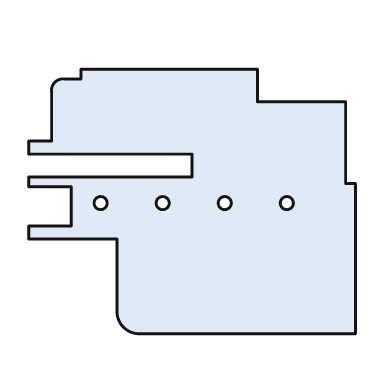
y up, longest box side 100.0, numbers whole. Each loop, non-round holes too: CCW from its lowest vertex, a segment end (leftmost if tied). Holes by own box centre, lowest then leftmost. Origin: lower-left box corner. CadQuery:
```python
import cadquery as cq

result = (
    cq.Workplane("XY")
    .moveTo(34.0, 0.0)
    .lineTo(100.0, 0.0)
    .lineTo(100.0, 46.0)
    .lineTo(97.0, 46.0)
    .lineTo(97.0, 71.0)
    .lineTo(70.0, 71.0)
    .lineTo(70.0, 81.0)
    .lineTo(16.0, 81.0)
    .lineTo(16.0, 78.0)
    .lineTo(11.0, 78.0)
    .threePointArc((8.0, 77.0), (7.0, 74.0))
    .lineTo(7.0, 59.0)
    .lineTo(0.0, 59.0)
    .lineTo(0.0, 55.0)
    .lineTo(50.0, 55.0)
    .lineTo(50.0, 48.0)
    .lineTo(0.0, 48.0)
    .lineTo(0.0, 45.0)
    .lineTo(13.0, 45.0)
    .lineTo(13.0, 33.0)
    .lineTo(0.0, 33.0)
    .lineTo(0.0, 29.0)
    .lineTo(27.0, 29.0)
    .lineTo(27.0, 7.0)
    .threePointArc((29.0, 2.0), (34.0, 0.0))
    .close()
    .moveTo(22.0, 40.0)
    .circle(2.0)
    .moveTo(41.0, 40.0)
    .circle(2.0)
    .moveTo(60.0, 40.0)
    .circle(2.0)
    .moveTo(79.0, 40.0)
    .circle(2.0)
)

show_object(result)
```